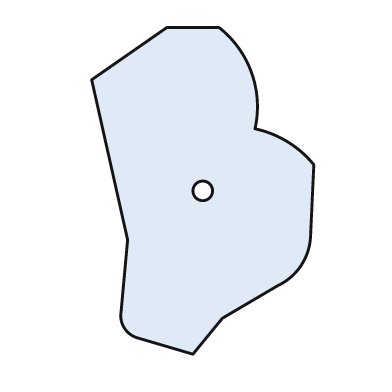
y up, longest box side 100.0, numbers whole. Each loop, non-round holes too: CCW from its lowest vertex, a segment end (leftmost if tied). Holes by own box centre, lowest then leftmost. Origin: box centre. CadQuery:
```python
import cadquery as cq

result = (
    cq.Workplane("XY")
    .moveTo(-3.0, -50.0)
    .lineTo(6.0, -39.0)
    .lineTo(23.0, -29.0)
    .threePointArc((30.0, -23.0), (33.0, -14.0))
    .lineTo(34.0, 8.0)
    .threePointArc((26.0, 15.0), (16.0, 19.0))
    .threePointArc((15.0, 36.0), (5.0, 50.0))
    .lineTo(-11.0, 50.0)
    .lineTo(-34.0, 34.0)
    .lineTo(-23.0, -15.0)
    .lineTo(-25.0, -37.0)
    .threePointArc((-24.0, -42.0), (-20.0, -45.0))
    .close()
    .moveTo(0.0, 0.0)
    .circle(3.0)
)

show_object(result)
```